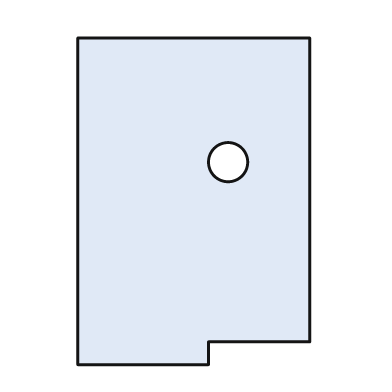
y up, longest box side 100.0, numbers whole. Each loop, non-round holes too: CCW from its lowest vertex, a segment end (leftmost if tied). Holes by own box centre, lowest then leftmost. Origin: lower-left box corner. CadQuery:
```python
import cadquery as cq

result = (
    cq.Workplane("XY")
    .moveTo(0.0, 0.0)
    .lineTo(40.0, 0.0)
    .lineTo(40.0, 7.0)
    .lineTo(71.0, 7.0)
    .lineTo(71.0, 100.0)
    .lineTo(0.0, 100.0)
    .close()
    .moveTo(46.0, 62.0)
    .circle(6.0)
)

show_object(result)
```